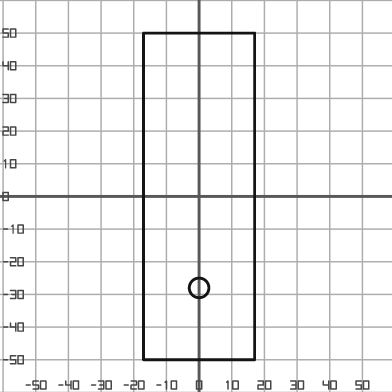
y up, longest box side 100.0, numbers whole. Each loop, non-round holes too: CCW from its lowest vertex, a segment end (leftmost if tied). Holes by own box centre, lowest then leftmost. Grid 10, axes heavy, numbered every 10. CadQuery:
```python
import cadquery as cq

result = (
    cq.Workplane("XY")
    .moveTo(-17.0, -50.0)
    .lineTo(17.0, -50.0)
    .lineTo(17.0, 50.0)
    .lineTo(-17.0, 50.0)
    .close()
    .moveTo(0.0, -28.0)
    .circle(3.0)
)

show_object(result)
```